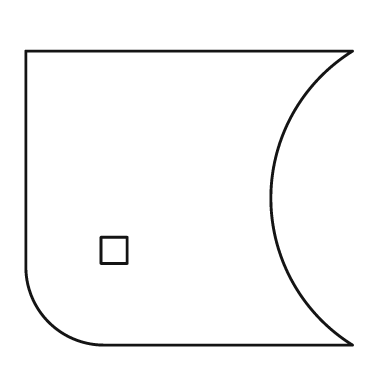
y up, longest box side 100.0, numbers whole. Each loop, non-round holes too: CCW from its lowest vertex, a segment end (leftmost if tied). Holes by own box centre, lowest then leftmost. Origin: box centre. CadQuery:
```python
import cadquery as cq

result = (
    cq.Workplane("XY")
    .moveTo(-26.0, -45.0)
    .lineTo(50.0, -45.0)
    .threePointArc((25.0, 0.0), (50.0, 45.0))
    .lineTo(-50.0, 45.0)
    .lineTo(-50.0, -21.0)
    .threePointArc((-43.0, -38.0), (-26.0, -45.0))
    .close()
    .moveTo(-27.0, -20.0)
    .lineTo(-19.0, -20.0)
    .lineTo(-19.0, -12.0)
    .lineTo(-27.0, -12.0)
    .close()
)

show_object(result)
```